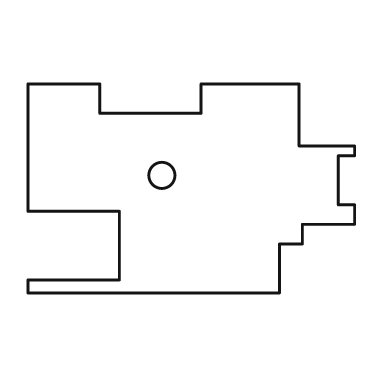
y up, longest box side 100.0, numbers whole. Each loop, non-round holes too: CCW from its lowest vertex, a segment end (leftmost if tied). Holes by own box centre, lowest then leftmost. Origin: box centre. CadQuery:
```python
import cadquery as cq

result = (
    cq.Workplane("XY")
    .moveTo(-50.0, -32.0)
    .lineTo(27.0, -32.0)
    .lineTo(27.0, -17.0)
    .lineTo(34.0, -17.0)
    .lineTo(34.0, -11.0)
    .lineTo(50.0, -11.0)
    .lineTo(50.0, -5.0)
    .lineTo(45.0, -5.0)
    .lineTo(45.0, 10.0)
    .lineTo(50.0, 10.0)
    .lineTo(50.0, 13.0)
    .lineTo(33.0, 13.0)
    .lineTo(33.0, 32.0)
    .lineTo(3.0, 32.0)
    .lineTo(3.0, 23.0)
    .lineTo(-28.0, 23.0)
    .lineTo(-28.0, 32.0)
    .lineTo(-50.0, 32.0)
    .lineTo(-50.0, -7.0)
    .lineTo(-22.0, -7.0)
    .lineTo(-22.0, -28.0)
    .lineTo(-50.0, -28.0)
    .close()
    .moveTo(-9.0, 4.0)
    .circle(4.0)
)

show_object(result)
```